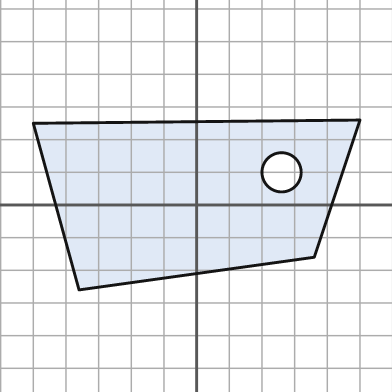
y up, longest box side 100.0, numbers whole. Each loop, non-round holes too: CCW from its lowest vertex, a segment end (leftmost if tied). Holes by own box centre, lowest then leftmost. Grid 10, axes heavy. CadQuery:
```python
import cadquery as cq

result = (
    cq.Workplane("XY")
    .moveTo(-36.0, -26.0)
    .lineTo(36.0, -16.0)
    .lineTo(50.0, 26.0)
    .lineTo(-50.0, 25.0)
    .close()
    .moveTo(26.0, 10.0)
    .circle(6.0)
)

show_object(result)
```